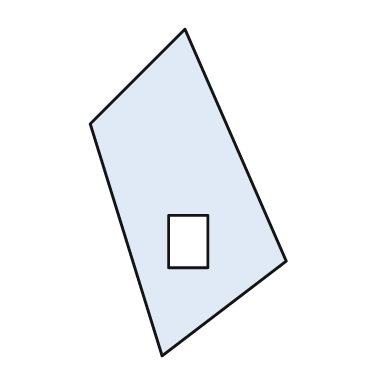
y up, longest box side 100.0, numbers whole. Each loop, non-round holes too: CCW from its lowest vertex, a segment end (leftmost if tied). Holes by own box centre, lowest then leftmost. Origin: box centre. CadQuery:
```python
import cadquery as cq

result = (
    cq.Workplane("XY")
    .moveTo(-8.0, -50.0)
    .lineTo(30.0, -21.0)
    .lineTo(-1.0, 50.0)
    .lineTo(-30.0, 21.0)
    .close()
    .moveTo(-6.0, -23.0)
    .lineTo(6.0, -23.0)
    .lineTo(6.0, -7.0)
    .lineTo(-6.0, -7.0)
    .close()
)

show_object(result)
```